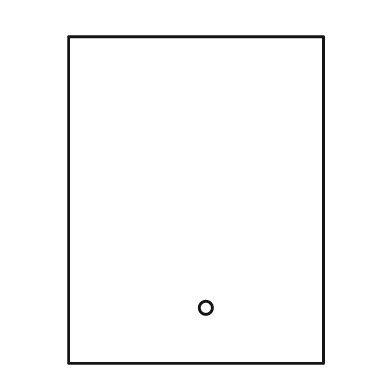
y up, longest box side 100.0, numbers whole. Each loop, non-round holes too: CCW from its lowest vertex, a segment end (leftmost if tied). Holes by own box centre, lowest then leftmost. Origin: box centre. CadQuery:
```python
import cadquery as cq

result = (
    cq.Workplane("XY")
    .moveTo(-39.0, -50.0)
    .lineTo(39.0, -50.0)
    .lineTo(39.0, 50.0)
    .lineTo(-39.0, 50.0)
    .close()
    .moveTo(3.0, -33.0)
    .circle(2.0)
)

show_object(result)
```